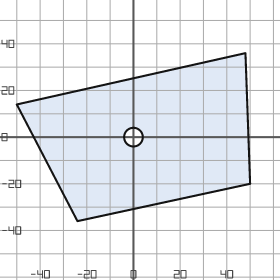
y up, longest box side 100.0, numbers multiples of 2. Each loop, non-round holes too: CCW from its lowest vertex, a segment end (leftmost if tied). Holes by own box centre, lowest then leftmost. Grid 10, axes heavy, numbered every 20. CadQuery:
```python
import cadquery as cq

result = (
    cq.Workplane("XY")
    .moveTo(-24.0, -36.0)
    .lineTo(50.0, -20.0)
    .lineTo(48.0, 36.0)
    .lineTo(-50.0, 14.0)
    .close()
    .moveTo(0.0, 0.0)
    .circle(4.0)
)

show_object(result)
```